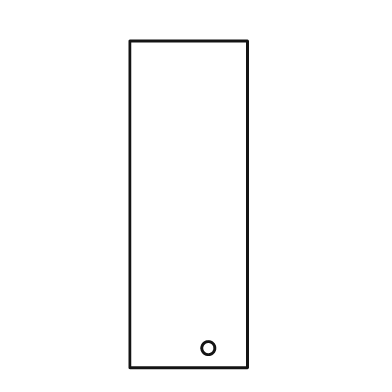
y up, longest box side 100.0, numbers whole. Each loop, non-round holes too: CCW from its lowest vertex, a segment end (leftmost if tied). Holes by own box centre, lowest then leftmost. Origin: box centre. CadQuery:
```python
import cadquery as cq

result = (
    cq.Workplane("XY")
    .moveTo(-18.0, -50.0)
    .lineTo(18.0, -50.0)
    .lineTo(18.0, 50.0)
    .lineTo(-18.0, 50.0)
    .close()
    .moveTo(6.0, -44.0)
    .circle(2.0)
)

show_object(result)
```